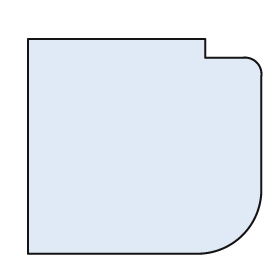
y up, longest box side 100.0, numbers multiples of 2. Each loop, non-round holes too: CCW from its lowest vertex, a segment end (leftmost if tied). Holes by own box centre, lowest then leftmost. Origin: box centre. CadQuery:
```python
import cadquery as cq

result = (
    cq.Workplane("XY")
    .moveTo(-50.0, -46.0)
    .lineTo(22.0, -46.0)
    .threePointArc((42.0, -38.0), (50.0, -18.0))
    .lineTo(50.0, 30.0)
    .threePointArc((48.0, 36.0), (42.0, 38.0))
    .lineTo(26.0, 38.0)
    .lineTo(26.0, 46.0)
    .lineTo(-50.0, 46.0)
    .close()
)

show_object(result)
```